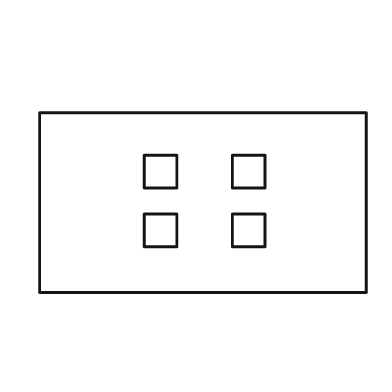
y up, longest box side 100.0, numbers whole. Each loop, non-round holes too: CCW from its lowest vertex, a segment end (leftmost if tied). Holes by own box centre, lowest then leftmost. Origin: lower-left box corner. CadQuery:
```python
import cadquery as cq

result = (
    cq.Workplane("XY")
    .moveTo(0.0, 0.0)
    .lineTo(100.0, 0.0)
    .lineTo(100.0, 55.0)
    .lineTo(0.0, 55.0)
    .close()
    .moveTo(32.0, 14.0)
    .lineTo(42.0, 14.0)
    .lineTo(42.0, 24.0)
    .lineTo(32.0, 24.0)
    .close()
    .moveTo(59.0, 14.0)
    .lineTo(69.0, 14.0)
    .lineTo(69.0, 24.0)
    .lineTo(59.0, 24.0)
    .close()
    .moveTo(32.0, 32.0)
    .lineTo(42.0, 32.0)
    .lineTo(42.0, 42.0)
    .lineTo(32.0, 42.0)
    .close()
    .moveTo(59.0, 32.0)
    .lineTo(69.0, 32.0)
    .lineTo(69.0, 42.0)
    .lineTo(59.0, 42.0)
    .close()
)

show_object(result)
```